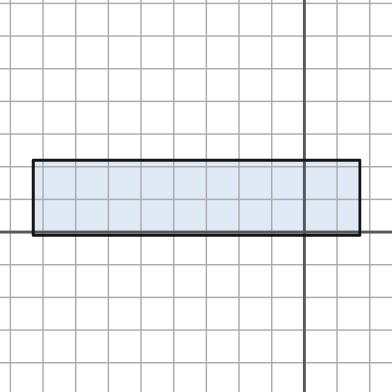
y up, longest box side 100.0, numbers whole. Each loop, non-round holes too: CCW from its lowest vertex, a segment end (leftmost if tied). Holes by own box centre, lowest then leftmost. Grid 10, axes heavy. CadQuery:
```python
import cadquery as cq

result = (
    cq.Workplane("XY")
    .moveTo(-83.0, -1.0)
    .lineTo(17.0, -1.0)
    .lineTo(17.0, 22.0)
    .lineTo(-83.0, 22.0)
    .close()
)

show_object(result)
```